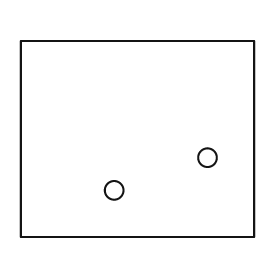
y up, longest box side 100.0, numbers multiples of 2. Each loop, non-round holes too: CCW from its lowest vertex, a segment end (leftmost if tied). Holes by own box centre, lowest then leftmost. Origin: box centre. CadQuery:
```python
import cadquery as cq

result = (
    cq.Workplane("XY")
    .moveTo(-50.0, -42.0)
    .lineTo(50.0, -42.0)
    .lineTo(50.0, 42.0)
    .lineTo(-50.0, 42.0)
    .close()
    .moveTo(-10.0, -22.0)
    .circle(4.0)
    .moveTo(30.0, -8.0)
    .circle(4.0)
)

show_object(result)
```